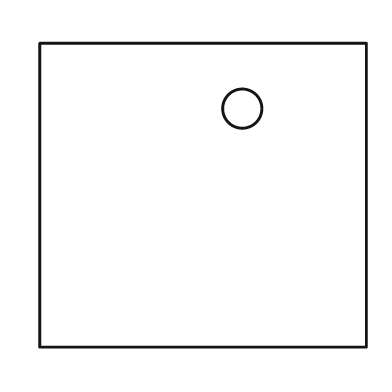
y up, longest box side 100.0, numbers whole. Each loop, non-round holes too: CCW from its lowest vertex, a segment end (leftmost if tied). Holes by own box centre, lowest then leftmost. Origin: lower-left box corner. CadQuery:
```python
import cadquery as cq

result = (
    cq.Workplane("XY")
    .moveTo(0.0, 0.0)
    .lineTo(100.0, 0.0)
    .lineTo(100.0, 93.0)
    .lineTo(0.0, 93.0)
    .close()
    .moveTo(62.0, 73.0)
    .circle(6.0)
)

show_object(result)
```